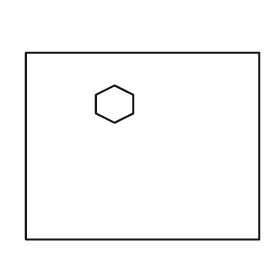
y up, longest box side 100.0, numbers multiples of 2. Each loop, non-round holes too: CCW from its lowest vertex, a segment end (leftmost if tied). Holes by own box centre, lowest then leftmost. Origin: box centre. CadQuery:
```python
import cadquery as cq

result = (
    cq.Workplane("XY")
    .moveTo(-50.0, -40.0)
    .lineTo(50.0, -40.0)
    .lineTo(50.0, 40.0)
    .lineTo(-50.0, 40.0)
    .close()
    .moveTo(-12.0, 10.0)
    .lineTo(-4.0, 14.0)
    .lineTo(-4.0, 22.0)
    .lineTo(-12.0, 26.0)
    .lineTo(-20.0, 22.0)
    .lineTo(-20.0, 14.0)
    .close()
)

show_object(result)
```